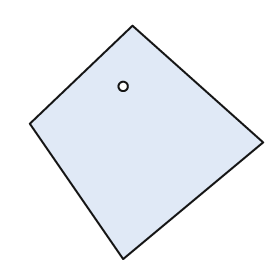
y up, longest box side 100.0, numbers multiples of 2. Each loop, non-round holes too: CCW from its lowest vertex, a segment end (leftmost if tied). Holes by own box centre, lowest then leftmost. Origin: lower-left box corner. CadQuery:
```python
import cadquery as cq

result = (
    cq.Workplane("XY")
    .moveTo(40.0, 0.0)
    .lineTo(100.0, 50.0)
    .lineTo(44.0, 100.0)
    .lineTo(0.0, 58.0)
    .close()
    .moveTo(40.0, 74.0)
    .circle(2.0)
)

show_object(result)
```